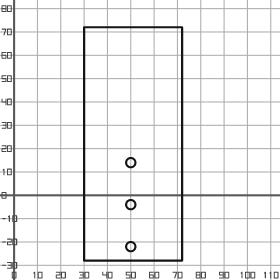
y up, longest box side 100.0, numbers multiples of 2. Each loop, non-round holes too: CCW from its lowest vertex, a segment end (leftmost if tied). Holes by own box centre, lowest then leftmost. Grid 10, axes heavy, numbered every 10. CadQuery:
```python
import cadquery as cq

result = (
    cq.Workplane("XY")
    .moveTo(30.0, -28.0)
    .lineTo(72.0, -28.0)
    .lineTo(72.0, 72.0)
    .lineTo(30.0, 72.0)
    .close()
    .moveTo(50.0, -22.0)
    .circle(2.0)
    .moveTo(50.0, -4.0)
    .circle(2.0)
    .moveTo(50.0, 14.0)
    .circle(2.0)
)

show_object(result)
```